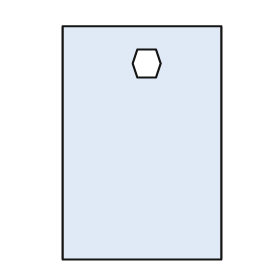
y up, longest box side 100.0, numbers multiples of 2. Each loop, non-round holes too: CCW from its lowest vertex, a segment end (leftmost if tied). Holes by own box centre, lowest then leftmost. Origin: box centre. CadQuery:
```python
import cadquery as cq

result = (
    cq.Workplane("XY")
    .moveTo(-34.0, -50.0)
    .lineTo(34.0, -50.0)
    .lineTo(34.0, 50.0)
    .lineTo(-34.0, 50.0)
    .close()
    .moveTo(-2.0, 28.0)
    .lineTo(6.0, 28.0)
    .lineTo(8.0, 34.0)
    .lineTo(6.0, 40.0)
    .lineTo(-2.0, 40.0)
    .lineTo(-4.0, 34.0)
    .close()
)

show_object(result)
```